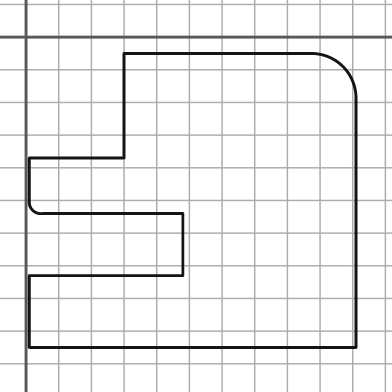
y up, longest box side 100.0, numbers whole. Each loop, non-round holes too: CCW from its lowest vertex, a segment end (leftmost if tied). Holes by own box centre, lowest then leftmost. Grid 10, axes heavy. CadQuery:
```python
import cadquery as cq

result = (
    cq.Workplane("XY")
    .moveTo(1.0, -95.0)
    .lineTo(101.0, -95.0)
    .lineTo(101.0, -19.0)
    .threePointArc((97.0, -9.0), (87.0, -5.0))
    .lineTo(30.0, -5.0)
    .lineTo(30.0, -37.0)
    .lineTo(1.0, -37.0)
    .lineTo(1.0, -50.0)
    .threePointArc((2.0, -53.0), (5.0, -54.0))
    .lineTo(48.0, -54.0)
    .lineTo(48.0, -73.0)
    .lineTo(1.0, -73.0)
    .close()
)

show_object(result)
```